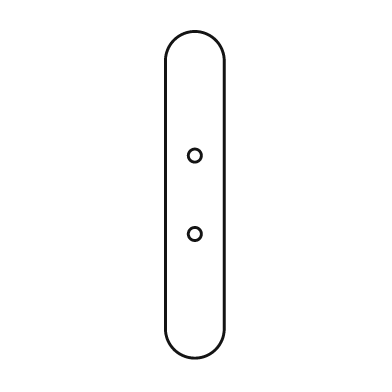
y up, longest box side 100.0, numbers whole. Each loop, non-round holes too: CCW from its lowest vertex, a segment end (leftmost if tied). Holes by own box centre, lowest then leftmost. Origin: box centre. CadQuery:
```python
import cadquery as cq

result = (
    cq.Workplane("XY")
    .moveTo(-9.0, -41.0)
    .threePointArc((0.0, -50.0), (9.0, -41.0))
    .lineTo(9.0, 41.0)
    .threePointArc((0.0, 50.0), (-9.0, 41.0))
    .close()
    .moveTo(0.0, -12.0)
    .circle(2.0)
    .moveTo(0.0, 12.0)
    .circle(2.0)
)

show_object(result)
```